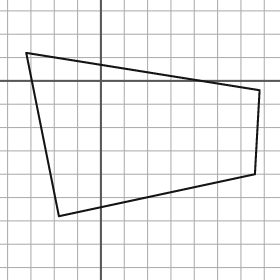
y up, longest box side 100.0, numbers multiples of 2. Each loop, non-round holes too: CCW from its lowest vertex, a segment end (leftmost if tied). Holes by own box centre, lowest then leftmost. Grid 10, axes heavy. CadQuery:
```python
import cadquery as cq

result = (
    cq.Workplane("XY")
    .moveTo(-18.0, -58.0)
    .lineTo(66.0, -40.0)
    .lineTo(68.0, -4.0)
    .lineTo(-32.0, 12.0)
    .close()
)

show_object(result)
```